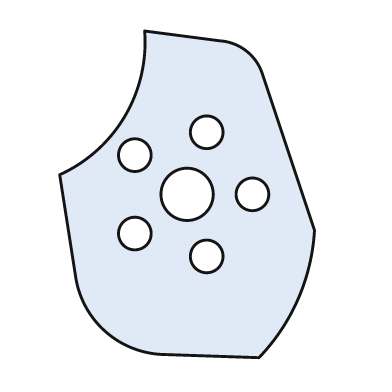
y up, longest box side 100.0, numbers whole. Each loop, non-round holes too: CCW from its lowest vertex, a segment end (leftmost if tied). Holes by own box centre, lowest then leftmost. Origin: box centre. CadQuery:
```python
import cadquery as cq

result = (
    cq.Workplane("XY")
    .moveTo(22.0, -50.0)
    .threePointArc((34.0, -32.0), (39.0, -11.0))
    .lineTo(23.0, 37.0)
    .threePointArc((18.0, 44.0), (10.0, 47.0))
    .lineTo(-13.0, 50.0)
    .threePointArc((-19.0, 24.0), (-39.0, 6.0))
    .lineTo(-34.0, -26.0)
    .threePointArc((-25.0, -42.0), (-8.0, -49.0))
    .close()
    .moveTo(6.0, -19.0)
    .circle(5.0)
    .moveTo(-16.0, -12.0)
    .circle(5.0)
    .moveTo(0.0, 0.0)
    .circle(8.0)
    .moveTo(20.0, 0.0)
    .circle(5.0)
    .moveTo(-16.0, 12.0)
    .circle(5.0)
    .moveTo(6.0, 19.0)
    .circle(5.0)
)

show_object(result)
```